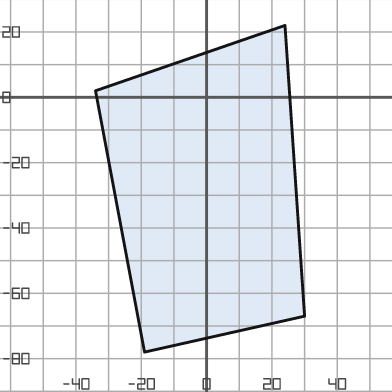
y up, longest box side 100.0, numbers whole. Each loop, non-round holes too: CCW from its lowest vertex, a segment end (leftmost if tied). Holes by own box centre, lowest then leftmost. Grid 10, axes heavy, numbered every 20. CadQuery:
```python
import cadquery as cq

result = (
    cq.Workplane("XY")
    .moveTo(-19.0, -78.0)
    .lineTo(30.0, -67.0)
    .lineTo(24.0, 22.0)
    .lineTo(-34.0, 2.0)
    .close()
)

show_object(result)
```